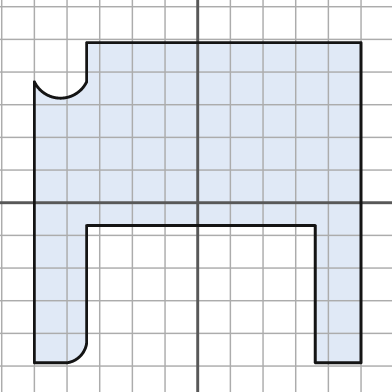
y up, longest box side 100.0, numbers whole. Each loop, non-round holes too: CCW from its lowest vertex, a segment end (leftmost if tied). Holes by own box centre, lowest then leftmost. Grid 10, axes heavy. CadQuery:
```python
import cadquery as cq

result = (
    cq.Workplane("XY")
    .moveTo(-50.0, -49.0)
    .lineTo(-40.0, -49.0)
    .threePointArc((-36.0, -47.0), (-34.0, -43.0))
    .lineTo(-34.0, -7.0)
    .lineTo(36.0, -7.0)
    .lineTo(36.0, -49.0)
    .lineTo(50.0, -49.0)
    .lineTo(50.0, 49.0)
    .lineTo(-34.0, 49.0)
    .lineTo(-34.0, 37.0)
    .threePointArc((-42.0, 32.0), (-50.0, 37.0))
    .close()
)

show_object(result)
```